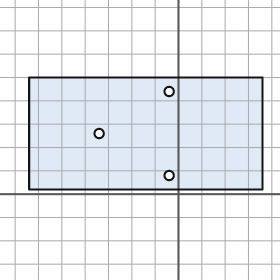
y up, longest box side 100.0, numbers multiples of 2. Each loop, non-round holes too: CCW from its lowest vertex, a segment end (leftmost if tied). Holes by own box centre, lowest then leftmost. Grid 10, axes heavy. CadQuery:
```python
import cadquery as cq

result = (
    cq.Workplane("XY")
    .moveTo(-64.0, 2.0)
    .lineTo(36.0, 2.0)
    .lineTo(36.0, 50.0)
    .lineTo(-64.0, 50.0)
    .close()
    .moveTo(-4.0, 8.0)
    .circle(2.0)
    .moveTo(-34.0, 26.0)
    .circle(2.0)
    .moveTo(-4.0, 44.0)
    .circle(2.0)
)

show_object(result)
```